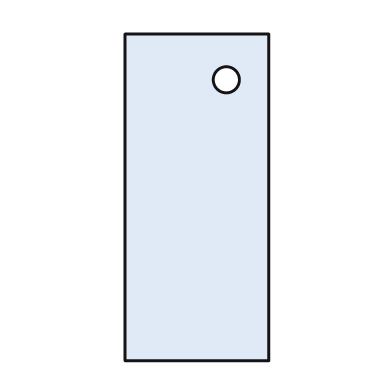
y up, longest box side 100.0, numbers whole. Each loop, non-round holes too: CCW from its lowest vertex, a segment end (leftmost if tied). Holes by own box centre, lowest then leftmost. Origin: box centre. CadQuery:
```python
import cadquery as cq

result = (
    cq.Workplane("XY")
    .moveTo(-22.0, -50.0)
    .lineTo(22.0, -50.0)
    .lineTo(22.0, 50.0)
    .lineTo(-22.0, 50.0)
    .close()
    .moveTo(9.0, 36.0)
    .circle(4.0)
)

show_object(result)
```